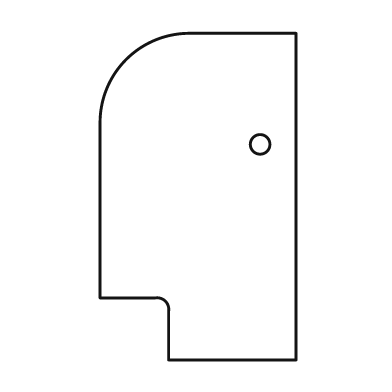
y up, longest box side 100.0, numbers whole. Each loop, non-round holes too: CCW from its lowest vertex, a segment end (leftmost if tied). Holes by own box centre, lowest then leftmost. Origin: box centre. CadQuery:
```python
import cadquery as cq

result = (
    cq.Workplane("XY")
    .moveTo(-9.0, -50.0)
    .lineTo(30.0, -50.0)
    .lineTo(30.0, 50.0)
    .lineTo(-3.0, 50.0)
    .threePointArc((-22.0, 42.0), (-30.0, 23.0))
    .lineTo(-30.0, -31.0)
    .lineTo(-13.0, -31.0)
    .threePointArc((-10.0, -32.0), (-9.0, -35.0))
    .close()
    .moveTo(19.0, 16.0)
    .circle(3.0)
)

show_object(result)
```